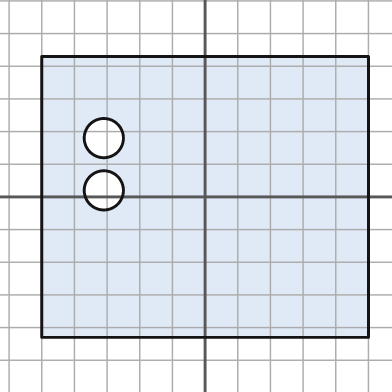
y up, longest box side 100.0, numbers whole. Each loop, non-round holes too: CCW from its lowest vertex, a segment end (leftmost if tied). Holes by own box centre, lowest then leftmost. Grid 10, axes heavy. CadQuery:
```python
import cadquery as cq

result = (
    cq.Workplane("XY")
    .moveTo(-50.0, -43.0)
    .lineTo(50.0, -43.0)
    .lineTo(50.0, 43.0)
    .lineTo(-50.0, 43.0)
    .close()
    .moveTo(-31.0, 2.0)
    .circle(6.0)
    .moveTo(-31.0, 18.0)
    .circle(6.0)
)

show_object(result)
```